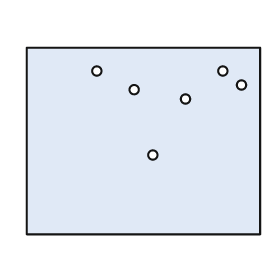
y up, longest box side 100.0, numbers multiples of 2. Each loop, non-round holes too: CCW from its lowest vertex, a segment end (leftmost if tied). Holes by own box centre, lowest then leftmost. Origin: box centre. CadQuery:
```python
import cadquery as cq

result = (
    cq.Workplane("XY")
    .moveTo(-50.0, -40.0)
    .lineTo(50.0, -40.0)
    .lineTo(50.0, 40.0)
    .lineTo(-50.0, 40.0)
    .close()
    .moveTo(4.0, -6.0)
    .circle(2.0)
    .moveTo(18.0, 18.0)
    .circle(2.0)
    .moveTo(-4.0, 22.0)
    .circle(2.0)
    .moveTo(42.0, 24.0)
    .circle(2.0)
    .moveTo(-20.0, 30.0)
    .circle(2.0)
    .moveTo(34.0, 30.0)
    .circle(2.0)
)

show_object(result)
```